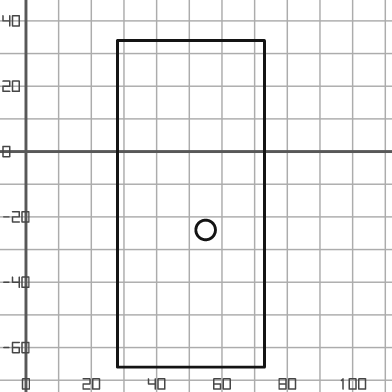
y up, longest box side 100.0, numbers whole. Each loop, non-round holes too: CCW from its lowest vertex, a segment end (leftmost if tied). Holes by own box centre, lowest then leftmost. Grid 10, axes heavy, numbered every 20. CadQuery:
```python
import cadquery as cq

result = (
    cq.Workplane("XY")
    .moveTo(28.0, -66.0)
    .lineTo(73.0, -66.0)
    .lineTo(73.0, 34.0)
    .lineTo(28.0, 34.0)
    .close()
    .moveTo(55.0, -24.0)
    .circle(3.0)
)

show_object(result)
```